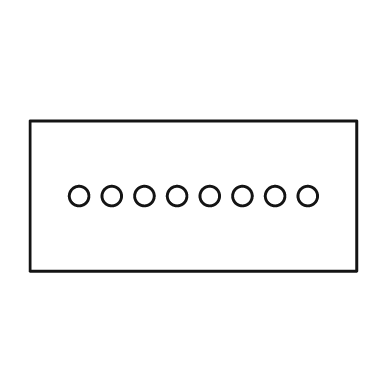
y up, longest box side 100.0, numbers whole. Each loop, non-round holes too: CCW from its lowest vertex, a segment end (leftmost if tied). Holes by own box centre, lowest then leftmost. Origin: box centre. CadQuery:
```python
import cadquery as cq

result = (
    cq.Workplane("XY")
    .moveTo(-50.0, -23.0)
    .lineTo(50.0, -23.0)
    .lineTo(50.0, 23.0)
    .lineTo(-50.0, 23.0)
    .close()
    .moveTo(-35.0, 0.0)
    .circle(3.0)
    .moveTo(-25.0, 0.0)
    .circle(3.0)
    .moveTo(-15.0, 0.0)
    .circle(3.0)
    .moveTo(-5.0, 0.0)
    .circle(3.0)
    .moveTo(5.0, 0.0)
    .circle(3.0)
    .moveTo(15.0, 0.0)
    .circle(3.0)
    .moveTo(25.0, 0.0)
    .circle(3.0)
    .moveTo(35.0, 0.0)
    .circle(3.0)
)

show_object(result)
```